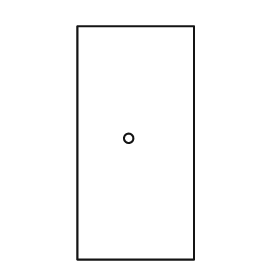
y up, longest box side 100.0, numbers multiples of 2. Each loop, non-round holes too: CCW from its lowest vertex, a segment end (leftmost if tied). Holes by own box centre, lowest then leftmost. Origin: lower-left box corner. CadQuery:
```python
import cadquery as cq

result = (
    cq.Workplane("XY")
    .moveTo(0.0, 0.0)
    .lineTo(50.0, 0.0)
    .lineTo(50.0, 100.0)
    .lineTo(0.0, 100.0)
    .close()
    .moveTo(22.0, 52.0)
    .circle(2.0)
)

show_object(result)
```